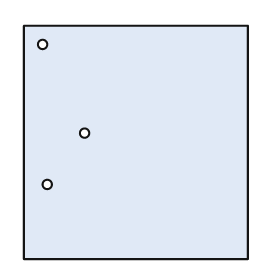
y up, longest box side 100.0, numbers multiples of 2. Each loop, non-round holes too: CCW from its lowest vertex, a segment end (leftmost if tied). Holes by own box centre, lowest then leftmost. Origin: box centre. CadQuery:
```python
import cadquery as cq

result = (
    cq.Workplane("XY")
    .moveTo(-48.0, -50.0)
    .lineTo(48.0, -50.0)
    .lineTo(48.0, 50.0)
    .lineTo(-48.0, 50.0)
    .close()
    .moveTo(-38.0, -18.0)
    .circle(2.0)
    .moveTo(-22.0, 4.0)
    .circle(2.0)
    .moveTo(-40.0, 42.0)
    .circle(2.0)
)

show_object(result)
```